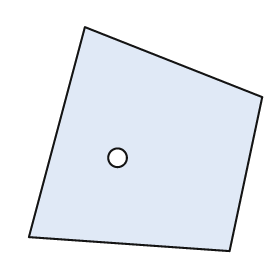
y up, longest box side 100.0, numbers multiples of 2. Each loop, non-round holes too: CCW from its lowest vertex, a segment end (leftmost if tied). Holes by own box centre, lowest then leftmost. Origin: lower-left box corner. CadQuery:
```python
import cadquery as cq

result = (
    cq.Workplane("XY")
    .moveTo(86.0, 0.0)
    .lineTo(100.0, 66.0)
    .lineTo(24.0, 96.0)
    .lineTo(0.0, 6.0)
    .close()
    .moveTo(38.0, 40.0)
    .circle(4.0)
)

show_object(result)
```